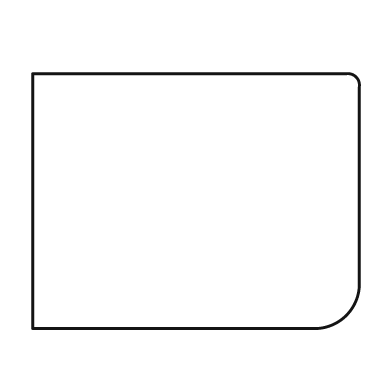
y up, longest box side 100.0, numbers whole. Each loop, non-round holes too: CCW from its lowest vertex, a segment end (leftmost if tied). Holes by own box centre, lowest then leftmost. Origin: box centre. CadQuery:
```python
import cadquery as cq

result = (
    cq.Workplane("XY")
    .moveTo(-50.0, -39.0)
    .lineTo(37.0, -39.0)
    .threePointArc((46.0, -35.0), (50.0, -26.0))
    .lineTo(50.0, 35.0)
    .threePointArc((49.0, 38.0), (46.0, 39.0))
    .lineTo(-50.0, 39.0)
    .close()
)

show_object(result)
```